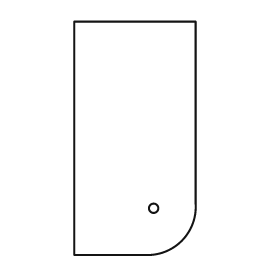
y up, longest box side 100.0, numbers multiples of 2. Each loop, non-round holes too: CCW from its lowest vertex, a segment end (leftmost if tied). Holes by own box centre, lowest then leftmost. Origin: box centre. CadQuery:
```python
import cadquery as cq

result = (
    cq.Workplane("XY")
    .moveTo(-26.0, -50.0)
    .lineTo(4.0, -50.0)
    .threePointArc((20.0, -44.0), (26.0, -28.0))
    .lineTo(26.0, 50.0)
    .lineTo(-26.0, 50.0)
    .close()
    .moveTo(8.0, -30.0)
    .circle(2.0)
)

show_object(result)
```